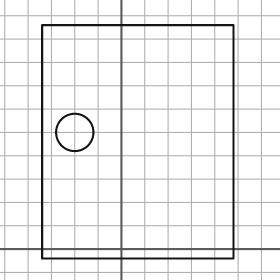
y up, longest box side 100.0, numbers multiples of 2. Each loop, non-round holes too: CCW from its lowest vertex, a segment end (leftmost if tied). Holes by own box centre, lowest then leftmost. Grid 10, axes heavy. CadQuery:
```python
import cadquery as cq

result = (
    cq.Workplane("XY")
    .moveTo(-34.0, -4.0)
    .lineTo(48.0, -4.0)
    .lineTo(48.0, 96.0)
    .lineTo(-34.0, 96.0)
    .close()
    .moveTo(-20.0, 50.0)
    .circle(8.0)
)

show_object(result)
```